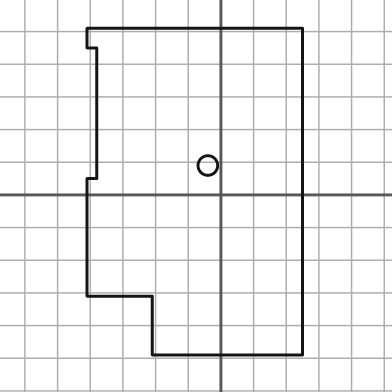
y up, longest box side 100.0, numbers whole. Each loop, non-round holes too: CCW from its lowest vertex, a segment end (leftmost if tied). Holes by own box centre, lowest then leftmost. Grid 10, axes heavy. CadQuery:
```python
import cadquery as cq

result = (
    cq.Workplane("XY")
    .moveTo(-21.0, -49.0)
    .lineTo(25.0, -49.0)
    .lineTo(25.0, 51.0)
    .lineTo(-41.0, 51.0)
    .lineTo(-41.0, 45.0)
    .lineTo(-38.0, 45.0)
    .lineTo(-38.0, 5.0)
    .lineTo(-41.0, 5.0)
    .lineTo(-41.0, -31.0)
    .lineTo(-21.0, -31.0)
    .close()
    .moveTo(-4.0, 9.0)
    .circle(3.0)
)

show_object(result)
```